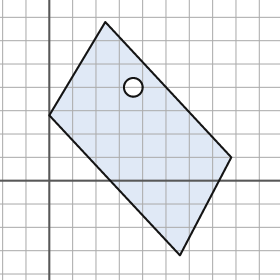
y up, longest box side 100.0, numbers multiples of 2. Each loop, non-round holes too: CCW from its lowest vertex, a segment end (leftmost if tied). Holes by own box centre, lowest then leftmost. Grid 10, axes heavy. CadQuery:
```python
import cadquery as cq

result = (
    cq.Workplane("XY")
    .moveTo(56.0, -32.0)
    .lineTo(78.0, 10.0)
    .lineTo(24.0, 68.0)
    .lineTo(0.0, 28.0)
    .close()
    .moveTo(36.0, 40.0)
    .circle(4.0)
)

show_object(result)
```